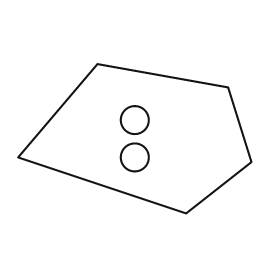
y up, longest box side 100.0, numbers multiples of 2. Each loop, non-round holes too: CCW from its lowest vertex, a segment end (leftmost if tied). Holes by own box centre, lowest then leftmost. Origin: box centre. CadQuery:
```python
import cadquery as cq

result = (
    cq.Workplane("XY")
    .moveTo(22.0, -32.0)
    .lineTo(50.0, -10.0)
    .lineTo(40.0, 22.0)
    .lineTo(-16.0, 32.0)
    .lineTo(-50.0, -8.0)
    .close()
    .moveTo(0.0, -8.0)
    .circle(6.0)
    .moveTo(0.0, 8.0)
    .circle(6.0)
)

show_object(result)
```